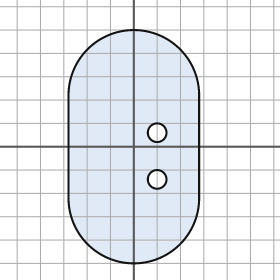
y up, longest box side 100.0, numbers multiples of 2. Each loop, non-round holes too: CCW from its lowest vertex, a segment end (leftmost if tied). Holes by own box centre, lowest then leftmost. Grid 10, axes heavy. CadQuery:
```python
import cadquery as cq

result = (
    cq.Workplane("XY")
    .moveTo(-28.0, -22.0)
    .threePointArc((0.0, -50.0), (28.0, -22.0))
    .lineTo(28.0, 22.0)
    .threePointArc((0.0, 50.0), (-28.0, 22.0))
    .close()
    .moveTo(10.0, -14.0)
    .circle(4.0)
    .moveTo(10.0, 6.0)
    .circle(4.0)
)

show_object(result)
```